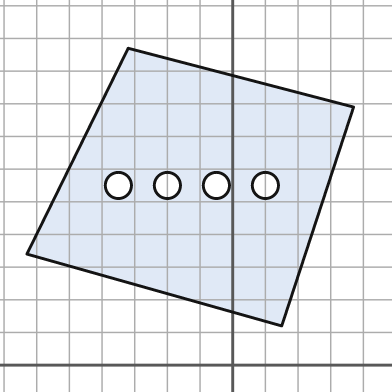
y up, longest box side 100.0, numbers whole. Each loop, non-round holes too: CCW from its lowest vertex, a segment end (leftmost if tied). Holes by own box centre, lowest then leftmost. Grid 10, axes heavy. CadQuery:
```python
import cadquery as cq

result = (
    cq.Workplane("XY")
    .moveTo(15.0, 12.0)
    .lineTo(37.0, 79.0)
    .lineTo(-32.0, 97.0)
    .lineTo(-63.0, 34.0)
    .close()
    .moveTo(-35.0, 55.0)
    .circle(4.0)
    .moveTo(-20.0, 55.0)
    .circle(4.0)
    .moveTo(-5.0, 55.0)
    .circle(4.0)
    .moveTo(10.0, 55.0)
    .circle(4.0)
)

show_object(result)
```